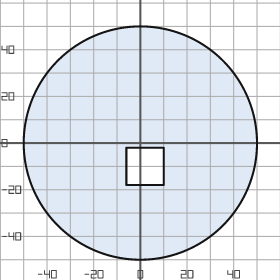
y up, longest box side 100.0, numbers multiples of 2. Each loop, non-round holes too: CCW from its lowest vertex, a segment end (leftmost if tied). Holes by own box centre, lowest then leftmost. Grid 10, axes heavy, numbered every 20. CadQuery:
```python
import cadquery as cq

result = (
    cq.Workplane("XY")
    .moveTo(0.0, 0.0)
    .circle(50.0)
    .moveTo(-6.0, -18.0)
    .lineTo(10.0, -18.0)
    .lineTo(10.0, -2.0)
    .lineTo(-6.0, -2.0)
    .close()
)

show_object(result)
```